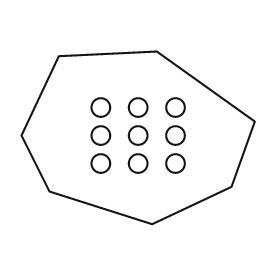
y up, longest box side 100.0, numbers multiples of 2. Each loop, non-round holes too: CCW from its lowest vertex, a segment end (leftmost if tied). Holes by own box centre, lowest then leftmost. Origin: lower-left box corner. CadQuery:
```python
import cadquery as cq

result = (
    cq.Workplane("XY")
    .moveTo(56.0, 0.0)
    .lineTo(90.0, 16.0)
    .lineTo(100.0, 44.0)
    .lineTo(58.0, 74.0)
    .lineTo(16.0, 72.0)
    .lineTo(0.0, 38.0)
    .lineTo(12.0, 14.0)
    .close()
    .moveTo(34.0, 26.0)
    .circle(4.0)
    .moveTo(50.0, 26.0)
    .circle(4.0)
    .moveTo(66.0, 26.0)
    .circle(4.0)
    .moveTo(34.0, 38.0)
    .circle(4.0)
    .moveTo(50.0, 38.0)
    .circle(4.0)
    .moveTo(66.0, 38.0)
    .circle(4.0)
    .moveTo(34.0, 50.0)
    .circle(4.0)
    .moveTo(50.0, 50.0)
    .circle(4.0)
    .moveTo(66.0, 50.0)
    .circle(4.0)
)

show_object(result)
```